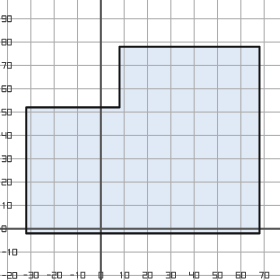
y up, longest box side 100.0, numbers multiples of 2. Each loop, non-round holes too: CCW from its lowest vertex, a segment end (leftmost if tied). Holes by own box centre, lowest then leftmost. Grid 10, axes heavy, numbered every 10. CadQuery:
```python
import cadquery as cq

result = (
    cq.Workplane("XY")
    .moveTo(-32.0, -2.0)
    .lineTo(68.0, -2.0)
    .lineTo(68.0, 78.0)
    .lineTo(8.0, 78.0)
    .lineTo(8.0, 52.0)
    .lineTo(-32.0, 52.0)
    .close()
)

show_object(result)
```